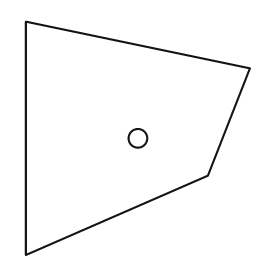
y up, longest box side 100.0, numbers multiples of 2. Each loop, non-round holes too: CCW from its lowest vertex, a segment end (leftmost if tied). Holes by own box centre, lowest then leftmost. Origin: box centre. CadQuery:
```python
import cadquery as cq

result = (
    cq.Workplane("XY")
    .moveTo(-48.0, -50.0)
    .lineTo(30.0, -16.0)
    .lineTo(48.0, 30.0)
    .lineTo(-48.0, 50.0)
    .close()
    .moveTo(0.0, 0.0)
    .circle(4.0)
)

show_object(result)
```